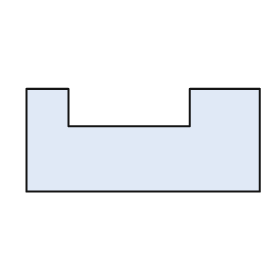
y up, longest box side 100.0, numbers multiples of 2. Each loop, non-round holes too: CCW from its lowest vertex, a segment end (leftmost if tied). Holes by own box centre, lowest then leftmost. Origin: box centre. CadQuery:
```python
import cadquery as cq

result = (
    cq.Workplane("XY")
    .moveTo(-50.0, -22.0)
    .lineTo(50.0, -22.0)
    .lineTo(50.0, 22.0)
    .lineTo(20.0, 22.0)
    .lineTo(20.0, 6.0)
    .lineTo(-32.0, 6.0)
    .lineTo(-32.0, 22.0)
    .lineTo(-50.0, 22.0)
    .close()
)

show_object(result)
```